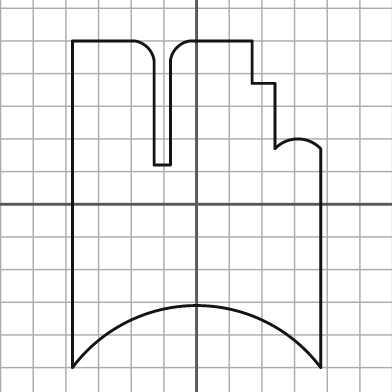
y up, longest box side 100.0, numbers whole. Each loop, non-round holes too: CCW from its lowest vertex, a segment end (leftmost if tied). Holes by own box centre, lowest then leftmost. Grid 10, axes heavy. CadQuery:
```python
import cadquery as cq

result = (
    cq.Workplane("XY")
    .moveTo(-38.0, -50.0)
    .threePointArc((0.0, -31.0), (38.0, -50.0))
    .lineTo(38.0, 17.0)
    .threePointArc((31.0, 20.0), (24.0, 17.0))
    .lineTo(24.0, 37.0)
    .lineTo(17.0, 37.0)
    .lineTo(17.0, 50.0)
    .lineTo(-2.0, 50.0)
    .threePointArc((-6.0, 48.0), (-8.0, 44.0))
    .lineTo(-8.0, 12.0)
    .lineTo(-13.0, 12.0)
    .lineTo(-13.0, 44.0)
    .threePointArc((-15.0, 48.0), (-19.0, 50.0))
    .lineTo(-38.0, 50.0)
    .close()
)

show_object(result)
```